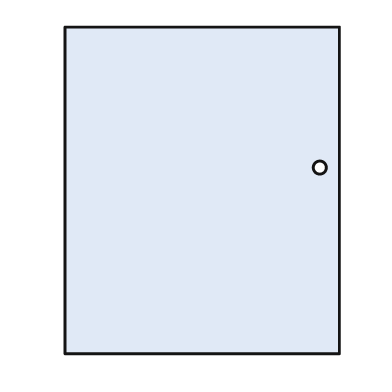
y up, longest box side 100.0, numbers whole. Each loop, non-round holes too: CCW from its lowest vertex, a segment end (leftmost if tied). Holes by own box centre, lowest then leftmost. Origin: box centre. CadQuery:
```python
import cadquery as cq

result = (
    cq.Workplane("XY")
    .moveTo(-42.0, -50.0)
    .lineTo(42.0, -50.0)
    .lineTo(42.0, 50.0)
    .lineTo(-42.0, 50.0)
    .close()
    .moveTo(36.0, 7.0)
    .circle(2.0)
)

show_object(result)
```